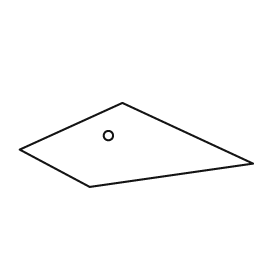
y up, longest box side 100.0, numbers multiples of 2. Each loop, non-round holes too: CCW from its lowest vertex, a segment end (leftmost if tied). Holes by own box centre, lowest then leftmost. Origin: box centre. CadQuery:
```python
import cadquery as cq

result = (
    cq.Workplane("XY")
    .moveTo(-20.0, -18.0)
    .lineTo(50.0, -8.0)
    .lineTo(-6.0, 18.0)
    .lineTo(-50.0, -2.0)
    .close()
    .moveTo(-12.0, 4.0)
    .circle(2.0)
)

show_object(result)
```